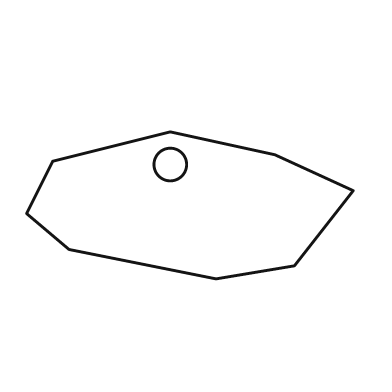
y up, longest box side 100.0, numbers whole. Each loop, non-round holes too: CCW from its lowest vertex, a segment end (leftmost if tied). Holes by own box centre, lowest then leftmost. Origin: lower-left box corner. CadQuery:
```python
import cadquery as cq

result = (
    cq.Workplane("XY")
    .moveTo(58.0, 0.0)
    .lineTo(82.0, 4.0)
    .lineTo(100.0, 27.0)
    .lineTo(76.0, 38.0)
    .lineTo(44.0, 45.0)
    .lineTo(8.0, 36.0)
    .lineTo(0.0, 20.0)
    .lineTo(13.0, 9.0)
    .close()
    .moveTo(44.0, 35.0)
    .circle(5.0)
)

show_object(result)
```